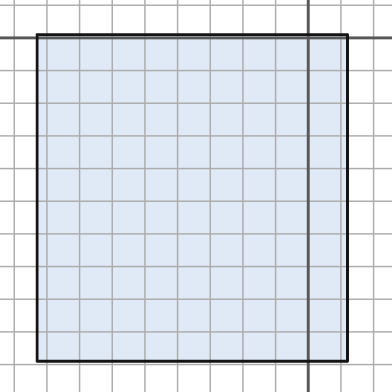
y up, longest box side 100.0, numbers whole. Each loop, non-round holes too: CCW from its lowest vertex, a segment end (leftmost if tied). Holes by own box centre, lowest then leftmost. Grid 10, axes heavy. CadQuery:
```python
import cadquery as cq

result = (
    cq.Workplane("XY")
    .moveTo(-83.0, -99.0)
    .lineTo(12.0, -99.0)
    .lineTo(12.0, 1.0)
    .lineTo(-83.0, 1.0)
    .close()
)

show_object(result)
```